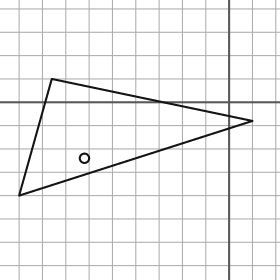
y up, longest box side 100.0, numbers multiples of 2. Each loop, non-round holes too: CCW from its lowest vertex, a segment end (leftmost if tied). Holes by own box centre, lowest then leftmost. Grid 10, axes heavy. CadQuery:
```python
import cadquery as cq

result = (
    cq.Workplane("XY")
    .moveTo(-90.0, -40.0)
    .lineTo(10.0, -8.0)
    .lineTo(-76.0, 10.0)
    .close()
    .moveTo(-62.0, -24.0)
    .circle(2.0)
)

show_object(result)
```